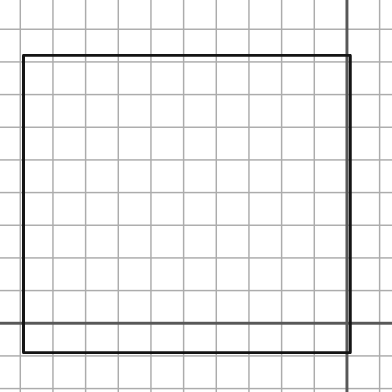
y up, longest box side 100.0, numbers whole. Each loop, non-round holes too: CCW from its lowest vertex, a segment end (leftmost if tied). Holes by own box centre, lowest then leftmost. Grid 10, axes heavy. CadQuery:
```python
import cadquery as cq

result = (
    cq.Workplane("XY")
    .moveTo(-99.0, -9.0)
    .lineTo(1.0, -9.0)
    .lineTo(1.0, 82.0)
    .lineTo(-99.0, 82.0)
    .close()
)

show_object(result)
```